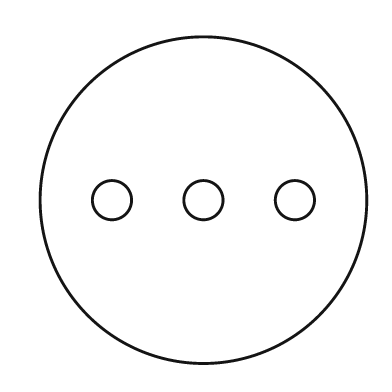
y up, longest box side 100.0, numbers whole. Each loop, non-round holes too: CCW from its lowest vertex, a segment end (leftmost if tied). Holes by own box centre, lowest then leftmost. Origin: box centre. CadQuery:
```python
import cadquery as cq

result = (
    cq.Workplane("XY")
    .moveTo(0.0, 0.0)
    .circle(50.0)
    .moveTo(-28.0, 0.0)
    .circle(6.0)
    .moveTo(0.0, 0.0)
    .circle(6.0)
    .moveTo(28.0, 0.0)
    .circle(6.0)
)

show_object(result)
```